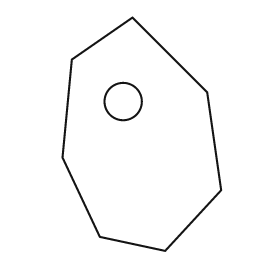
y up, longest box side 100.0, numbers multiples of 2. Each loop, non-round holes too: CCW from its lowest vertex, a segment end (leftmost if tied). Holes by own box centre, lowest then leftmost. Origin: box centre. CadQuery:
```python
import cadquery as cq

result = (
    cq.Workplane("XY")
    .moveTo(10.0, -50.0)
    .lineTo(34.0, -24.0)
    .lineTo(28.0, 18.0)
    .lineTo(-4.0, 50.0)
    .lineTo(-30.0, 32.0)
    .lineTo(-34.0, -10.0)
    .lineTo(-18.0, -44.0)
    .close()
    .moveTo(-8.0, 14.0)
    .circle(8.0)
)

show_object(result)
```